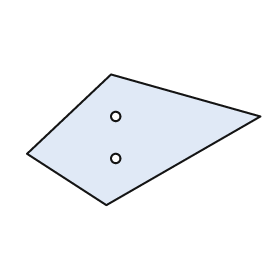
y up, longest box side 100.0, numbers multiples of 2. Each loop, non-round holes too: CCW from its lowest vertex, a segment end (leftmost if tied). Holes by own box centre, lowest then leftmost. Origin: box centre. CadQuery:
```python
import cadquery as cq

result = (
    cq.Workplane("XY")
    .moveTo(-16.0, -28.0)
    .lineTo(50.0, 10.0)
    .lineTo(-14.0, 28.0)
    .lineTo(-50.0, -6.0)
    .close()
    .moveTo(-12.0, -8.0)
    .circle(2.0)
    .moveTo(-12.0, 10.0)
    .circle(2.0)
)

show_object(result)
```